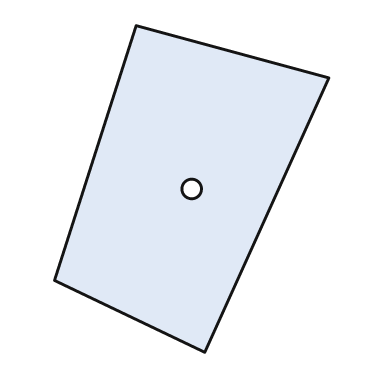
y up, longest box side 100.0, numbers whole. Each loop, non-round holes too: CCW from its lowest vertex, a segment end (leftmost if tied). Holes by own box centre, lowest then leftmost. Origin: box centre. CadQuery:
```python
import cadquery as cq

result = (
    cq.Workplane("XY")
    .moveTo(4.0, -50.0)
    .lineTo(42.0, 34.0)
    .lineTo(-17.0, 50.0)
    .lineTo(-42.0, -28.0)
    .close()
    .moveTo(0.0, 0.0)
    .circle(3.0)
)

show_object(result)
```